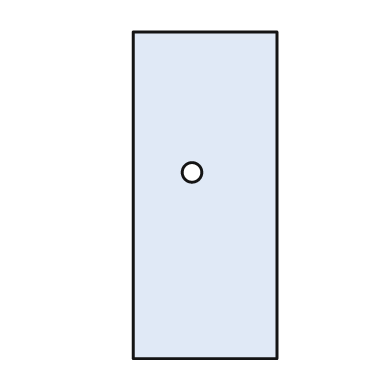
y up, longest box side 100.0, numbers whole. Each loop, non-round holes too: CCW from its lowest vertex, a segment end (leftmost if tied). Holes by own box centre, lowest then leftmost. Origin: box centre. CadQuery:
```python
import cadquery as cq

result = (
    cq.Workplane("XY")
    .moveTo(-22.0, -50.0)
    .lineTo(22.0, -50.0)
    .lineTo(22.0, 50.0)
    .lineTo(-22.0, 50.0)
    .close()
    .moveTo(-4.0, 7.0)
    .circle(3.0)
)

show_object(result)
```